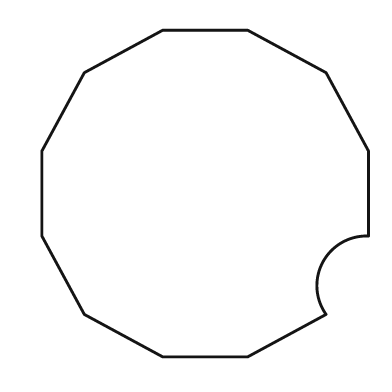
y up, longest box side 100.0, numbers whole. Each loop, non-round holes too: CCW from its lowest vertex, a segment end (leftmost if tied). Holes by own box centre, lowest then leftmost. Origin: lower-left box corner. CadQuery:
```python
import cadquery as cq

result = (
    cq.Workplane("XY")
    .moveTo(37.0, 0.0)
    .lineTo(63.0, 0.0)
    .lineTo(87.0, 13.0)
    .threePointArc((86.0, 29.0), (100.0, 37.0))
    .lineTo(100.0, 63.0)
    .lineTo(87.0, 87.0)
    .lineTo(63.0, 100.0)
    .lineTo(37.0, 100.0)
    .lineTo(13.0, 87.0)
    .lineTo(0.0, 63.0)
    .lineTo(0.0, 37.0)
    .lineTo(13.0, 13.0)
    .close()
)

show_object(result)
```